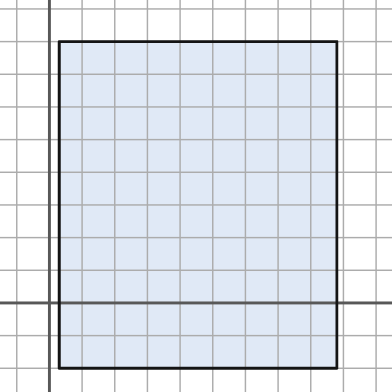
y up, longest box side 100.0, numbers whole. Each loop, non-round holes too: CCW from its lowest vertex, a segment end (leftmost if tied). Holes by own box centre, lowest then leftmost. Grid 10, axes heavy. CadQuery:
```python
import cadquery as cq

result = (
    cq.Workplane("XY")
    .moveTo(3.0, -20.0)
    .lineTo(88.0, -20.0)
    .lineTo(88.0, 80.0)
    .lineTo(3.0, 80.0)
    .close()
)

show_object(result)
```